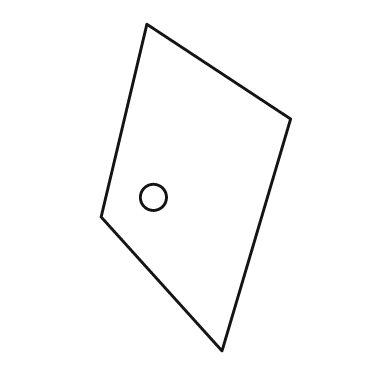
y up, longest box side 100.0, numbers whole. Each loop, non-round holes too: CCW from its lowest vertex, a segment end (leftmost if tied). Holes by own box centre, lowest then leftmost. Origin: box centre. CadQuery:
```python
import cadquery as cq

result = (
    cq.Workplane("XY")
    .moveTo(8.0, -50.0)
    .lineTo(29.0, 21.0)
    .lineTo(-15.0, 50.0)
    .lineTo(-29.0, -9.0)
    .close()
    .moveTo(-13.0, -3.0)
    .circle(4.0)
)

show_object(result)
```